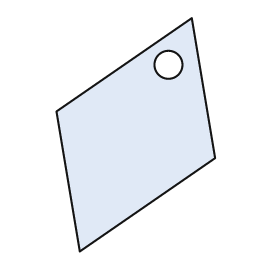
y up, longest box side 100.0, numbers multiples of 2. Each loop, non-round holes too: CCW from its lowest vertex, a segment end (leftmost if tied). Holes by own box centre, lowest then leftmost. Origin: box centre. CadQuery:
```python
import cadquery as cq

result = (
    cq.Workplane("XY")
    .moveTo(-24.0, -50.0)
    .lineTo(34.0, -10.0)
    .lineTo(24.0, 50.0)
    .lineTo(-34.0, 10.0)
    .close()
    .moveTo(14.0, 30.0)
    .circle(6.0)
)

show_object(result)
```